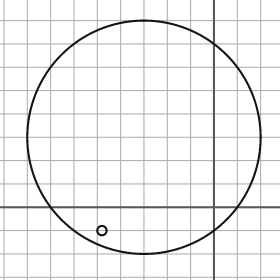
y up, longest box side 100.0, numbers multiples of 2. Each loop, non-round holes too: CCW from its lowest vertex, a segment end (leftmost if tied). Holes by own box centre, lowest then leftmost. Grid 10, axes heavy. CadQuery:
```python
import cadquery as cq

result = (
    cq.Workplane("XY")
    .moveTo(-30.0, 30.0)
    .circle(50.0)
    .moveTo(-48.0, -10.0)
    .circle(2.0)
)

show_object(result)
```